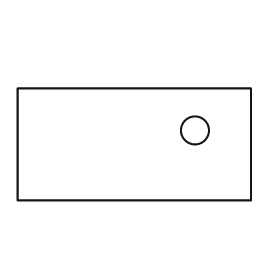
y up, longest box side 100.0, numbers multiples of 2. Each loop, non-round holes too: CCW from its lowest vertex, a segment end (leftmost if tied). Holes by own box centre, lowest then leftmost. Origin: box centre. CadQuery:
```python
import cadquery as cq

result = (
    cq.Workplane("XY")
    .moveTo(-50.0, -24.0)
    .lineTo(50.0, -24.0)
    .lineTo(50.0, 24.0)
    .lineTo(-50.0, 24.0)
    .close()
    .moveTo(26.0, 6.0)
    .circle(6.0)
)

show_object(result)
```